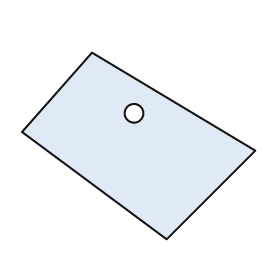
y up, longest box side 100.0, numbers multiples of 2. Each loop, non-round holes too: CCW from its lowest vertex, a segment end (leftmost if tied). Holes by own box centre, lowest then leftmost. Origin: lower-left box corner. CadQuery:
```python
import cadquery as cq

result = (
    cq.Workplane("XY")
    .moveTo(62.0, 0.0)
    .lineTo(100.0, 38.0)
    .lineTo(30.0, 80.0)
    .lineTo(0.0, 46.0)
    .close()
    .moveTo(48.0, 54.0)
    .circle(4.0)
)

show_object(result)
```